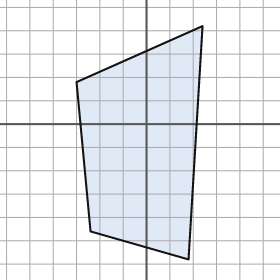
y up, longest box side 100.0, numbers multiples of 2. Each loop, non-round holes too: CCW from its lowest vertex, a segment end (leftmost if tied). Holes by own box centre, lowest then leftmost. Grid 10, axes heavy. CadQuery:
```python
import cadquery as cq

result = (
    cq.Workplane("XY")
    .moveTo(18.0, -58.0)
    .lineTo(24.0, 42.0)
    .lineTo(-30.0, 18.0)
    .lineTo(-24.0, -46.0)
    .close()
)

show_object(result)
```